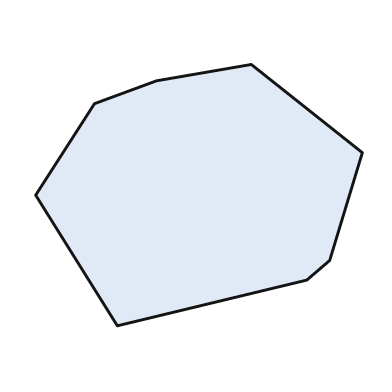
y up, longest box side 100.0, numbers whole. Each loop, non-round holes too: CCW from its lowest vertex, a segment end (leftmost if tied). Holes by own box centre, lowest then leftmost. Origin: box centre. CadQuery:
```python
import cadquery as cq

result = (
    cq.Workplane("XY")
    .moveTo(-25.0, -40.0)
    .lineTo(33.0, -26.0)
    .lineTo(40.0, -20.0)
    .lineTo(50.0, 13.0)
    .lineTo(16.0, 40.0)
    .lineTo(-13.0, 35.0)
    .lineTo(-32.0, 28.0)
    .lineTo(-50.0, 0.0)
    .close()
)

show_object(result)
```